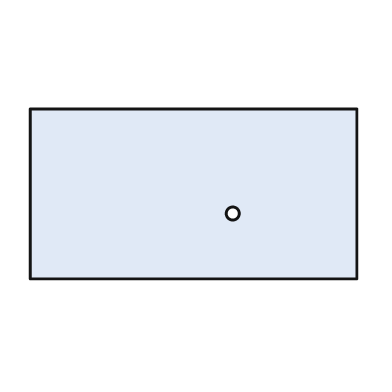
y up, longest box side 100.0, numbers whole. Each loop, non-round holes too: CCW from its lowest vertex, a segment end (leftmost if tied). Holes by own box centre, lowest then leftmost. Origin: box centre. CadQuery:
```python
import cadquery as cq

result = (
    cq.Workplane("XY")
    .moveTo(-50.0, -26.0)
    .lineTo(50.0, -26.0)
    .lineTo(50.0, 26.0)
    .lineTo(-50.0, 26.0)
    .close()
    .moveTo(12.0, -6.0)
    .circle(2.0)
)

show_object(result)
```